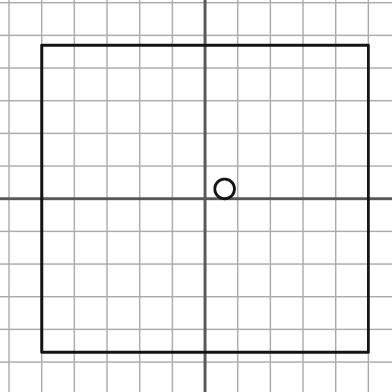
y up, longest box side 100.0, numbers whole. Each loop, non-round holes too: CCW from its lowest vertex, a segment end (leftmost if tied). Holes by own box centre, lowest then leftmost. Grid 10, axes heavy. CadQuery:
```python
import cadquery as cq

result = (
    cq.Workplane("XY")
    .moveTo(-50.0, -47.0)
    .lineTo(50.0, -47.0)
    .lineTo(50.0, 47.0)
    .lineTo(-50.0, 47.0)
    .close()
    .moveTo(6.0, 3.0)
    .circle(3.0)
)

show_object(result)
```